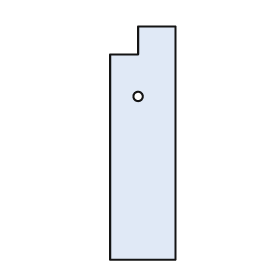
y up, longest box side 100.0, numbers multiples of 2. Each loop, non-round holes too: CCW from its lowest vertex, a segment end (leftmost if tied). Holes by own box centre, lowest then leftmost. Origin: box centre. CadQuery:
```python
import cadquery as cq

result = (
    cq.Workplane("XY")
    .moveTo(-14.0, -50.0)
    .lineTo(14.0, -50.0)
    .lineTo(14.0, 50.0)
    .lineTo(-2.0, 50.0)
    .lineTo(-2.0, 38.0)
    .lineTo(-14.0, 38.0)
    .close()
    .moveTo(-2.0, 20.0)
    .circle(2.0)
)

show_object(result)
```